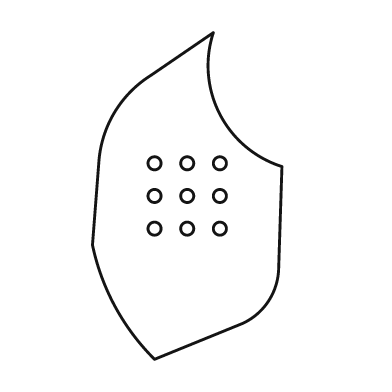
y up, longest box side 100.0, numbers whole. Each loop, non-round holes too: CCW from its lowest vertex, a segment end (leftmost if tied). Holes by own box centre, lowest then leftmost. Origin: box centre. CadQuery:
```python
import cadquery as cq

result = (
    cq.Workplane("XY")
    .moveTo(-10.0, -50.0)
    .lineTo(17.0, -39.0)
    .threePointArc((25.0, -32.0), (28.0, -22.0))
    .lineTo(29.0, 9.0)
    .threePointArc((10.0, 25.0), (8.0, 50.0))
    .lineTo(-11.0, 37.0)
    .threePointArc((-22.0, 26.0), (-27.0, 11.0))
    .lineTo(-29.0, -15.0)
    .threePointArc((-22.0, -34.0), (-10.0, -50.0))
    .close()
    .moveTo(-10.0, -10.0)
    .circle(2.0)
    .moveTo(0.0, -10.0)
    .circle(2.0)
    .moveTo(10.0, -10.0)
    .circle(2.0)
    .moveTo(-10.0, 0.0)
    .circle(2.0)
    .moveTo(0.0, 0.0)
    .circle(2.0)
    .moveTo(10.0, 0.0)
    .circle(2.0)
    .moveTo(-10.0, 10.0)
    .circle(2.0)
    .moveTo(0.0, 10.0)
    .circle(2.0)
    .moveTo(10.0, 10.0)
    .circle(2.0)
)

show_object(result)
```